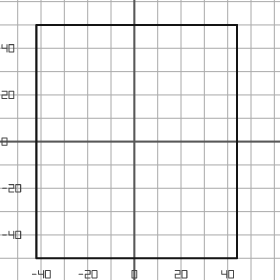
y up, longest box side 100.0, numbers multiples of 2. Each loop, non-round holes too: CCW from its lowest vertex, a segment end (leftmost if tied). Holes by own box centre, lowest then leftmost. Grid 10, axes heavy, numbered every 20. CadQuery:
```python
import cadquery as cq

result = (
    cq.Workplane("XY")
    .moveTo(-42.0, -50.0)
    .lineTo(44.0, -50.0)
    .lineTo(44.0, 50.0)
    .lineTo(-42.0, 50.0)
    .close()
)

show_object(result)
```